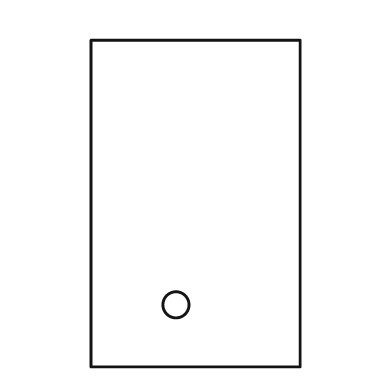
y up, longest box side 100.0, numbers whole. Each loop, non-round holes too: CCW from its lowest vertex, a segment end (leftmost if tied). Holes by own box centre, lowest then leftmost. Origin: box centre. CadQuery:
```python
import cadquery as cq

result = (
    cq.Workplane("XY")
    .moveTo(-32.0, -50.0)
    .lineTo(32.0, -50.0)
    .lineTo(32.0, 50.0)
    .lineTo(-32.0, 50.0)
    .close()
    .moveTo(-6.0, -31.0)
    .circle(4.0)
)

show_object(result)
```